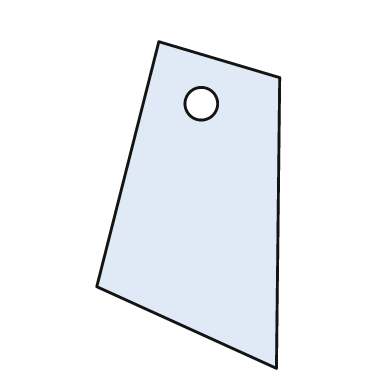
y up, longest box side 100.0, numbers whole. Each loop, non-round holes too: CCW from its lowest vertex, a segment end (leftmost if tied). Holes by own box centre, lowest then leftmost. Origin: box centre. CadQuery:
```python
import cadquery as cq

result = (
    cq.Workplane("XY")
    .moveTo(27.0, -50.0)
    .lineTo(28.0, 39.0)
    .lineTo(-9.0, 50.0)
    .lineTo(-28.0, -25.0)
    .close()
    .moveTo(4.0, 31.0)
    .circle(5.0)
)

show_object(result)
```